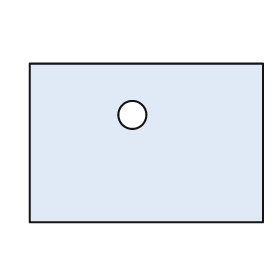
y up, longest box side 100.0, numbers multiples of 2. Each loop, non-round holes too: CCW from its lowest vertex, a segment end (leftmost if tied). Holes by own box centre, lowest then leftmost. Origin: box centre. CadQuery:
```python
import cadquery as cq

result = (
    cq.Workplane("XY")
    .moveTo(-50.0, -34.0)
    .lineTo(50.0, -34.0)
    .lineTo(50.0, 34.0)
    .lineTo(-50.0, 34.0)
    .close()
    .moveTo(-6.0, 12.0)
    .circle(6.0)
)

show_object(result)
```